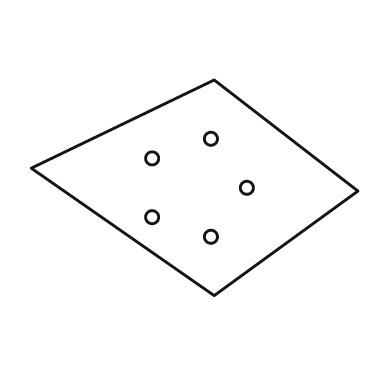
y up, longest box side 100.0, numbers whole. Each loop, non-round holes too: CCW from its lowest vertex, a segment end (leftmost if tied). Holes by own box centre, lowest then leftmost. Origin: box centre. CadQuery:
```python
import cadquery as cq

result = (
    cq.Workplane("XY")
    .moveTo(6.0, -33.0)
    .lineTo(50.0, -1.0)
    .lineTo(6.0, 33.0)
    .lineTo(-50.0, 6.0)
    .close()
    .moveTo(5.0, -15.0)
    .circle(2.0)
    .moveTo(-13.0, -9.0)
    .circle(2.0)
    .moveTo(16.0, 0.0)
    .circle(2.0)
    .moveTo(-13.0, 9.0)
    .circle(2.0)
    .moveTo(5.0, 15.0)
    .circle(2.0)
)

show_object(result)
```